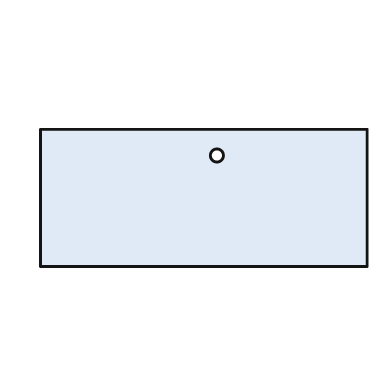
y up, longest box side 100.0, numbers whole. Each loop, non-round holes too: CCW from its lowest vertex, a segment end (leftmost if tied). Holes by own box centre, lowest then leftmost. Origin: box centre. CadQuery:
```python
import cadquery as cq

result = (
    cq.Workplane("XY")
    .moveTo(-50.0, -21.0)
    .lineTo(50.0, -21.0)
    .lineTo(50.0, 21.0)
    .lineTo(-50.0, 21.0)
    .close()
    .moveTo(4.0, 13.0)
    .circle(2.0)
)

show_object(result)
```